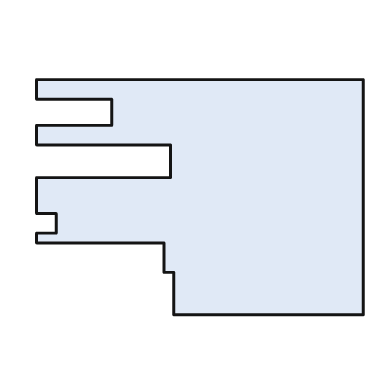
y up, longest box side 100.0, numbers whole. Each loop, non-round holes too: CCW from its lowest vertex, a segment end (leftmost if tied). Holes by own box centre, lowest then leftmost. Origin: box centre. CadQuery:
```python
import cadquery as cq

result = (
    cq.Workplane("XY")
    .moveTo(-8.0, -36.0)
    .lineTo(50.0, -36.0)
    .lineTo(50.0, 36.0)
    .lineTo(-50.0, 36.0)
    .lineTo(-50.0, 30.0)
    .lineTo(-27.0, 30.0)
    .lineTo(-27.0, 22.0)
    .lineTo(-50.0, 22.0)
    .lineTo(-50.0, 16.0)
    .lineTo(-9.0, 16.0)
    .lineTo(-9.0, 6.0)
    .lineTo(-50.0, 6.0)
    .lineTo(-50.0, -5.0)
    .lineTo(-44.0, -5.0)
    .lineTo(-44.0, -11.0)
    .lineTo(-50.0, -11.0)
    .lineTo(-50.0, -14.0)
    .lineTo(-11.0, -14.0)
    .lineTo(-11.0, -23.0)
    .lineTo(-8.0, -23.0)
    .close()
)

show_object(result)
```